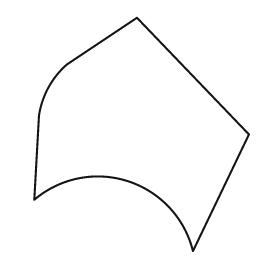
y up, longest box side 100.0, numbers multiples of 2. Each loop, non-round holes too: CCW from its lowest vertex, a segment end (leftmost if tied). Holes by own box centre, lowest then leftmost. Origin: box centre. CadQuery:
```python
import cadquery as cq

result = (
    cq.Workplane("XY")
    .moveTo(22.0, -50.0)
    .lineTo(46.0, 0.0)
    .lineTo(-2.0, 50.0)
    .lineTo(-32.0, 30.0)
    .threePointArc((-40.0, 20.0), (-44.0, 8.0))
    .lineTo(-46.0, -28.0)
    .threePointArc((-6.0, -20.0), (22.0, -50.0))
    .close()
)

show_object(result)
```